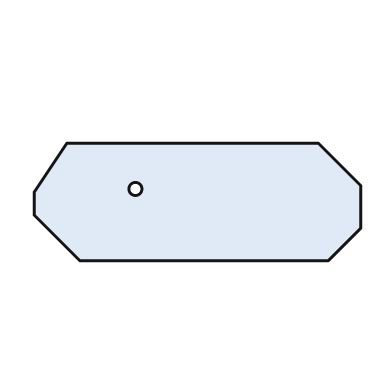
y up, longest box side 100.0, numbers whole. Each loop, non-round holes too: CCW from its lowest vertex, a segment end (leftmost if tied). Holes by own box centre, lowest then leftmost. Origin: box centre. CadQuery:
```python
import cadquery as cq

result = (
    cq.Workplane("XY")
    .moveTo(-36.0, -18.0)
    .lineTo(40.0, -18.0)
    .lineTo(50.0, -8.0)
    .lineTo(50.0, 5.0)
    .lineTo(37.0, 18.0)
    .lineTo(-40.0, 18.0)
    .lineTo(-50.0, 3.0)
    .lineTo(-50.0, -4.0)
    .close()
    .moveTo(-19.0, 4.0)
    .circle(2.0)
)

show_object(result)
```